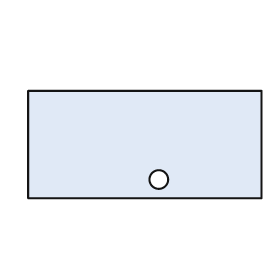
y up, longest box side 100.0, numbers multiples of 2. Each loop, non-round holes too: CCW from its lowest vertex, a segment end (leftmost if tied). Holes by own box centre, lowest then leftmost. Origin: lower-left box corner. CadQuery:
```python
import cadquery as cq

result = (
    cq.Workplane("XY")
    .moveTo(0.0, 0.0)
    .lineTo(100.0, 0.0)
    .lineTo(100.0, 46.0)
    .lineTo(0.0, 46.0)
    .close()
    .moveTo(56.0, 8.0)
    .circle(4.0)
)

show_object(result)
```